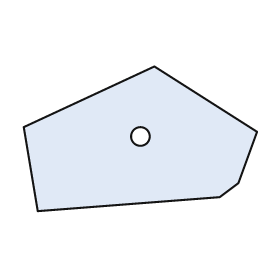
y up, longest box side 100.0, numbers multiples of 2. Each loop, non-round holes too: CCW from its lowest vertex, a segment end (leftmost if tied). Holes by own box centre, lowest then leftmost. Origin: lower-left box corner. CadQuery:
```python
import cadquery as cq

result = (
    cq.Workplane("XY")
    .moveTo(6.0, 0.0)
    .lineTo(84.0, 6.0)
    .lineTo(92.0, 12.0)
    .lineTo(100.0, 34.0)
    .lineTo(56.0, 62.0)
    .lineTo(0.0, 36.0)
    .close()
    .moveTo(50.0, 32.0)
    .circle(4.0)
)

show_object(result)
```